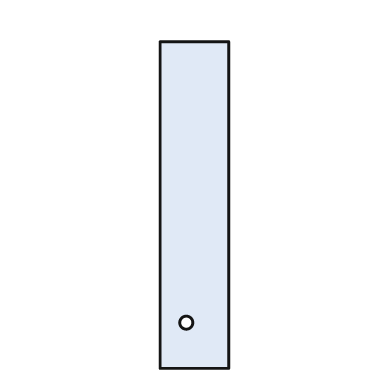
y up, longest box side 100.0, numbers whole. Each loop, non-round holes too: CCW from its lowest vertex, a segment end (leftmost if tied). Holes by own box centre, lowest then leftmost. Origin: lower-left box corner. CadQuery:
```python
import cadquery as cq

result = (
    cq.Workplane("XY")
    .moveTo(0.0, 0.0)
    .lineTo(21.0, 0.0)
    .lineTo(21.0, 100.0)
    .lineTo(0.0, 100.0)
    .close()
    .moveTo(8.0, 14.0)
    .circle(2.0)
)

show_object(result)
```